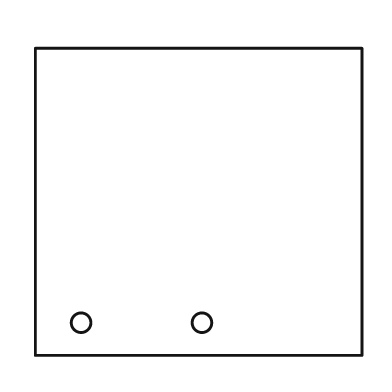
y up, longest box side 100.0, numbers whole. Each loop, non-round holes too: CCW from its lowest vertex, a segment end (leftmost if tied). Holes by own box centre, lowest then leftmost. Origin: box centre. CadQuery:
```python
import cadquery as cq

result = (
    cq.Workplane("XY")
    .moveTo(-50.0, -47.0)
    .lineTo(50.0, -47.0)
    .lineTo(50.0, 47.0)
    .lineTo(-50.0, 47.0)
    .close()
    .moveTo(-36.0, -37.0)
    .circle(3.0)
    .moveTo(1.0, -37.0)
    .circle(3.0)
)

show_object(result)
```